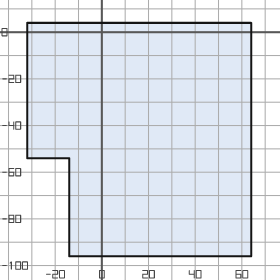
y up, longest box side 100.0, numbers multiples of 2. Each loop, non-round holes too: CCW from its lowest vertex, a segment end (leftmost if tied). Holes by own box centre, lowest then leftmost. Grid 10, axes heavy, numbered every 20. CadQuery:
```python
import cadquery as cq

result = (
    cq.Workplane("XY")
    .moveTo(-14.0, -96.0)
    .lineTo(64.0, -96.0)
    .lineTo(64.0, 4.0)
    .lineTo(-32.0, 4.0)
    .lineTo(-32.0, -54.0)
    .lineTo(-14.0, -54.0)
    .close()
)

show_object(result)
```